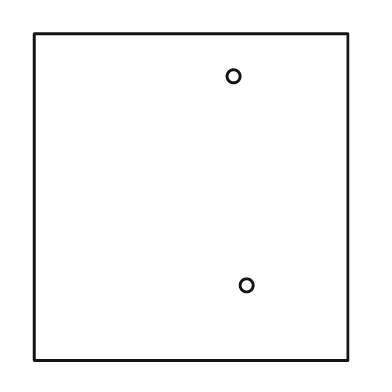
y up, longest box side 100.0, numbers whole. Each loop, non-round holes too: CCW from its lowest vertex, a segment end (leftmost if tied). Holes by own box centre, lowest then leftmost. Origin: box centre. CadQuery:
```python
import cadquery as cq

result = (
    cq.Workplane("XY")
    .moveTo(-48.0, -50.0)
    .lineTo(48.0, -50.0)
    .lineTo(48.0, 50.0)
    .lineTo(-48.0, 50.0)
    .close()
    .moveTo(17.0, -27.0)
    .circle(2.0)
    .moveTo(13.0, 37.0)
    .circle(2.0)
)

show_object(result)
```